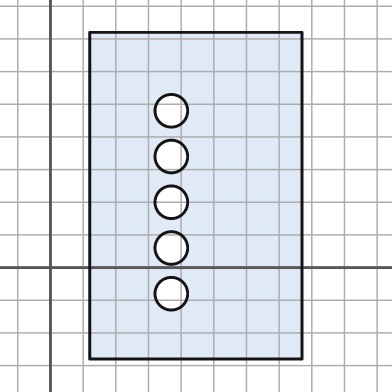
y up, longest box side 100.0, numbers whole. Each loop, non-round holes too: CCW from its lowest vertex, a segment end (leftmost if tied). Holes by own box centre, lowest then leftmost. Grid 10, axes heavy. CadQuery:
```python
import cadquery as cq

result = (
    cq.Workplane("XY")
    .moveTo(12.0, -28.0)
    .lineTo(77.0, -28.0)
    .lineTo(77.0, 72.0)
    .lineTo(12.0, 72.0)
    .close()
    .moveTo(37.0, -8.0)
    .circle(5.0)
    .moveTo(37.0, 6.0)
    .circle(5.0)
    .moveTo(37.0, 20.0)
    .circle(5.0)
    .moveTo(37.0, 34.0)
    .circle(5.0)
    .moveTo(37.0, 48.0)
    .circle(5.0)
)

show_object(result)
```